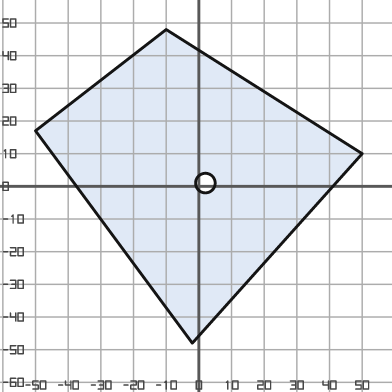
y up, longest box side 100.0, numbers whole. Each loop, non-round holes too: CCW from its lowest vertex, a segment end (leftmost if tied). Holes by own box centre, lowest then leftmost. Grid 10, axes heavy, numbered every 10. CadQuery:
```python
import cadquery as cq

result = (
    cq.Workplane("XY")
    .moveTo(-2.0, -48.0)
    .lineTo(50.0, 10.0)
    .lineTo(-10.0, 48.0)
    .lineTo(-50.0, 17.0)
    .close()
    .moveTo(2.0, 1.0)
    .circle(3.0)
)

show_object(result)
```